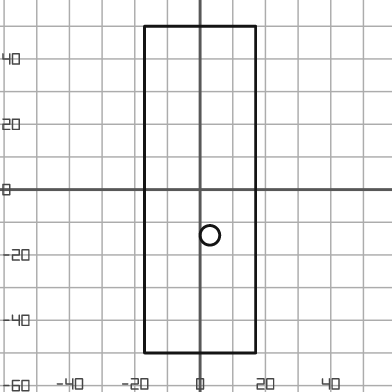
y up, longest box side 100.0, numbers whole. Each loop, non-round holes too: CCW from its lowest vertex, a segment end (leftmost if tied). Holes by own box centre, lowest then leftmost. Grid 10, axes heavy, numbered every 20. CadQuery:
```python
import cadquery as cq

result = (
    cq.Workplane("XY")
    .moveTo(-17.0, -50.0)
    .lineTo(17.0, -50.0)
    .lineTo(17.0, 50.0)
    .lineTo(-17.0, 50.0)
    .close()
    .moveTo(3.0, -14.0)
    .circle(3.0)
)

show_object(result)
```